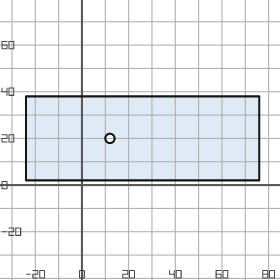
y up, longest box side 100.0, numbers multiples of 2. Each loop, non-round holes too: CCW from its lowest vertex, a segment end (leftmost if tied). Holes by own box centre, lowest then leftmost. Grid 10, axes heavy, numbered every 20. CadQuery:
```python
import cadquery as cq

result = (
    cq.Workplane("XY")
    .moveTo(-24.0, 2.0)
    .lineTo(76.0, 2.0)
    .lineTo(76.0, 38.0)
    .lineTo(-24.0, 38.0)
    .close()
    .moveTo(12.0, 20.0)
    .circle(2.0)
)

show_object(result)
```